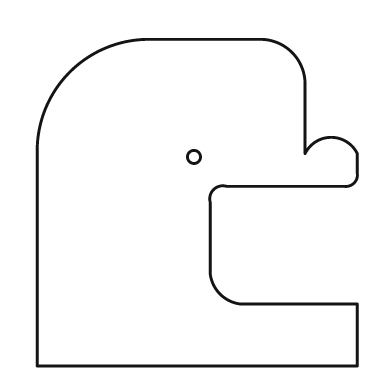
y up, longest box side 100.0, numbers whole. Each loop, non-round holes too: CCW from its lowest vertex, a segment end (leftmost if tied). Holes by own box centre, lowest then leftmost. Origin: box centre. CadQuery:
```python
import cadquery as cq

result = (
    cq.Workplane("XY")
    .moveTo(-49.0, -50.0)
    .lineTo(49.0, -50.0)
    .lineTo(49.0, -31.0)
    .lineTo(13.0, -31.0)
    .threePointArc((7.0, -28.0), (4.0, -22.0))
    .lineTo(4.0, 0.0)
    .threePointArc((5.0, 4.0), (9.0, 5.0))
    .lineTo(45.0, 5.0)
    .threePointArc((48.0, 6.0), (49.0, 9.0))
    .lineTo(49.0, 15.0)
    .threePointArc((41.0, 20.0), (33.0, 15.0))
    .lineTo(33.0, 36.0)
    .threePointArc((29.0, 46.0), (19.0, 50.0))
    .lineTo(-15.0, 50.0)
    .threePointArc((-39.0, 40.0), (-49.0, 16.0))
    .close()
    .moveTo(-1.0, 14.0)
    .circle(2.0)
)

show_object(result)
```